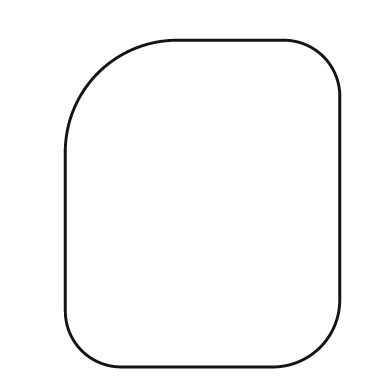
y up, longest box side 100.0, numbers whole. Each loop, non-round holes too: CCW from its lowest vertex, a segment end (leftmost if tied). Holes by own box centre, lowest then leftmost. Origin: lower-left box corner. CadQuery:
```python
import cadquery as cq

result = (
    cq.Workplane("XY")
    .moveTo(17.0, 0.0)
    .lineTo(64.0, 0.0)
    .threePointArc((78.0, 6.0), (84.0, 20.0))
    .lineTo(84.0, 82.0)
    .threePointArc((79.0, 95.0), (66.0, 100.0))
    .lineTo(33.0, 100.0)
    .threePointArc((10.0, 90.0), (0.0, 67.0))
    .lineTo(0.0, 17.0)
    .threePointArc((5.0, 5.0), (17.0, 0.0))
    .close()
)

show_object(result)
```